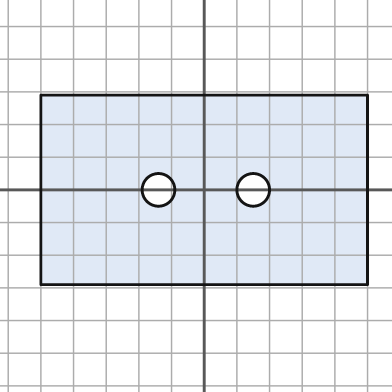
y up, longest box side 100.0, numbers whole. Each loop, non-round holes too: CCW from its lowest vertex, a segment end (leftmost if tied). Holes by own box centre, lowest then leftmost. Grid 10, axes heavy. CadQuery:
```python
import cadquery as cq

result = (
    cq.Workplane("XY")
    .moveTo(-50.0, -29.0)
    .lineTo(50.0, -29.0)
    .lineTo(50.0, 29.0)
    .lineTo(-50.0, 29.0)
    .close()
    .moveTo(-14.0, 0.0)
    .circle(5.0)
    .moveTo(15.0, 0.0)
    .circle(5.0)
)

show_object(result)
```